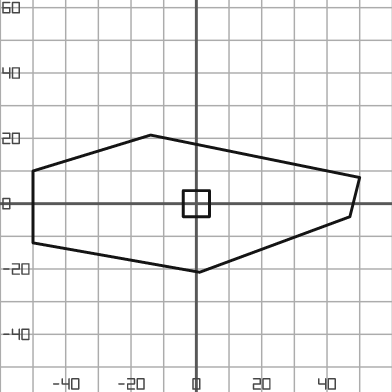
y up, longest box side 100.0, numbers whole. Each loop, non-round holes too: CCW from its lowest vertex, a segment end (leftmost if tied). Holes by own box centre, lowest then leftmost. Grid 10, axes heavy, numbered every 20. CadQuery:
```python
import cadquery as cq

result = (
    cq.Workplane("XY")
    .moveTo(1.0, -21.0)
    .lineTo(47.0, -4.0)
    .lineTo(50.0, 8.0)
    .lineTo(-14.0, 21.0)
    .lineTo(-50.0, 10.0)
    .lineTo(-50.0, -12.0)
    .close()
    .moveTo(-4.0, -4.0)
    .lineTo(4.0, -4.0)
    .lineTo(4.0, 4.0)
    .lineTo(-4.0, 4.0)
    .close()
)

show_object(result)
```